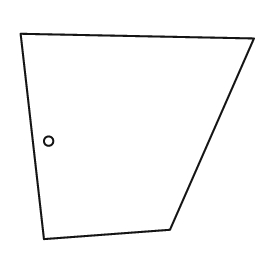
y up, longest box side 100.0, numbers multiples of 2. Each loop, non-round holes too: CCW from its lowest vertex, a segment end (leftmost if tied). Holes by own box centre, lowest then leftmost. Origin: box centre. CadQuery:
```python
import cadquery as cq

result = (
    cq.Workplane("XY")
    .moveTo(-40.0, -44.0)
    .lineTo(14.0, -40.0)
    .lineTo(50.0, 42.0)
    .lineTo(-50.0, 44.0)
    .close()
    .moveTo(-38.0, -2.0)
    .circle(2.0)
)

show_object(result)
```